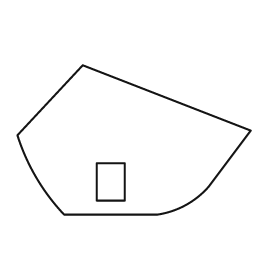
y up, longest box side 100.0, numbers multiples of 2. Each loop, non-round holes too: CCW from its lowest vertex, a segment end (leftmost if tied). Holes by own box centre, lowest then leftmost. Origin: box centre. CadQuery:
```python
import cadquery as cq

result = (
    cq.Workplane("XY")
    .moveTo(-30.0, -32.0)
    .lineTo(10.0, -32.0)
    .threePointArc((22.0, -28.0), (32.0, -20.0))
    .lineTo(50.0, 4.0)
    .lineTo(-22.0, 32.0)
    .lineTo(-50.0, 2.0)
    .threePointArc((-42.0, -16.0), (-30.0, -32.0))
    .close()
    .moveTo(-16.0, -26.0)
    .lineTo(-4.0, -26.0)
    .lineTo(-4.0, -10.0)
    .lineTo(-16.0, -10.0)
    .close()
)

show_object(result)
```